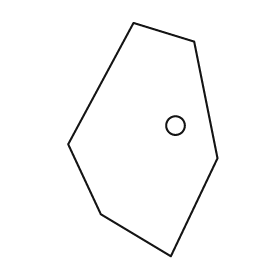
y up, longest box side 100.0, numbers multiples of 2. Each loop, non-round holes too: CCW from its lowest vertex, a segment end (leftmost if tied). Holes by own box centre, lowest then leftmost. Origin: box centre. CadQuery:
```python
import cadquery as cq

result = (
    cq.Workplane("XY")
    .moveTo(12.0, -50.0)
    .lineTo(32.0, -8.0)
    .lineTo(22.0, 42.0)
    .lineTo(-4.0, 50.0)
    .lineTo(-32.0, -2.0)
    .lineTo(-18.0, -32.0)
    .close()
    .moveTo(14.0, 6.0)
    .circle(4.0)
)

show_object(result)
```